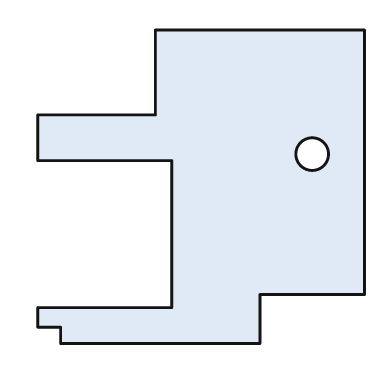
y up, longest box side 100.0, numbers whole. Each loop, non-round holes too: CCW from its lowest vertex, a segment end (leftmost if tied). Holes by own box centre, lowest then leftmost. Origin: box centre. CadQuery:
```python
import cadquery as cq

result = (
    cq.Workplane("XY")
    .moveTo(-43.0, -48.0)
    .lineTo(18.0, -48.0)
    .lineTo(18.0, -33.0)
    .lineTo(50.0, -33.0)
    .lineTo(50.0, 48.0)
    .lineTo(-14.0, 48.0)
    .lineTo(-14.0, 22.0)
    .lineTo(-50.0, 22.0)
    .lineTo(-50.0, 8.0)
    .lineTo(-9.0, 8.0)
    .lineTo(-9.0, -37.0)
    .lineTo(-50.0, -37.0)
    .lineTo(-50.0, -43.0)
    .lineTo(-43.0, -43.0)
    .close()
    .moveTo(34.0, 10.0)
    .circle(5.0)
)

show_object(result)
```